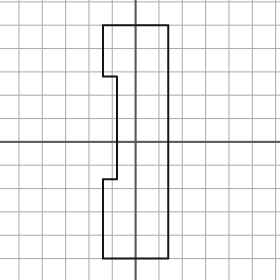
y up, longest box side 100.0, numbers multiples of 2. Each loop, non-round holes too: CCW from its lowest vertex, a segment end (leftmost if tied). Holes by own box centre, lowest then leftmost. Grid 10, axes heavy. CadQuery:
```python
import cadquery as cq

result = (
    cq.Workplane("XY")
    .moveTo(-14.0, -50.0)
    .lineTo(14.0, -50.0)
    .lineTo(14.0, 50.0)
    .lineTo(-14.0, 50.0)
    .lineTo(-14.0, 28.0)
    .lineTo(-8.0, 28.0)
    .lineTo(-8.0, -16.0)
    .lineTo(-14.0, -16.0)
    .close()
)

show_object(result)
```